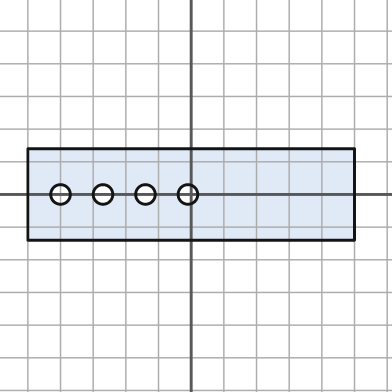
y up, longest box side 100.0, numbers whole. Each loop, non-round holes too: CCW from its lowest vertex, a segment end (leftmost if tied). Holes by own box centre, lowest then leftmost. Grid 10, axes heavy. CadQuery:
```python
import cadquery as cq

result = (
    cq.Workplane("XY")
    .moveTo(-50.0, -14.0)
    .lineTo(50.0, -14.0)
    .lineTo(50.0, 14.0)
    .lineTo(-50.0, 14.0)
    .close()
    .moveTo(-40.0, 0.0)
    .circle(3.0)
    .moveTo(-27.0, 0.0)
    .circle(3.0)
    .moveTo(-14.0, 0.0)
    .circle(3.0)
    .moveTo(-1.0, 0.0)
    .circle(3.0)
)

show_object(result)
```